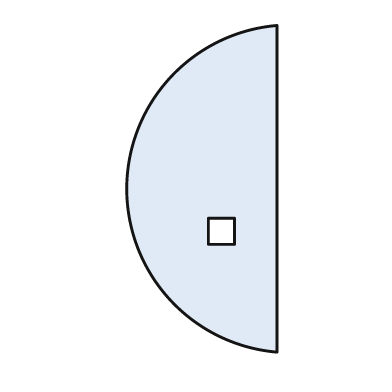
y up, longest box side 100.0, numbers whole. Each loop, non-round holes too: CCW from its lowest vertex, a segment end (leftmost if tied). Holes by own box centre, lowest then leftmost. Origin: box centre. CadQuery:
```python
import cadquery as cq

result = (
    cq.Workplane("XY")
    .moveTo(23.0, -50.0)
    .lineTo(23.0, 50.0)
    .threePointArc((-23.0, 0.0), (23.0, -50.0))
    .close()
    .moveTo(2.0, -17.0)
    .lineTo(10.0, -17.0)
    .lineTo(10.0, -9.0)
    .lineTo(2.0, -9.0)
    .close()
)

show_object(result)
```